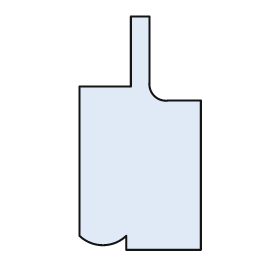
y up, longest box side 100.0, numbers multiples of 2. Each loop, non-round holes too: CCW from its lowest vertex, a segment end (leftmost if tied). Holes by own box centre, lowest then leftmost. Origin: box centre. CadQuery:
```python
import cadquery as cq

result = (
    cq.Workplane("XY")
    .moveTo(-6.0, -50.0)
    .lineTo(26.0, -50.0)
    .lineTo(26.0, 14.0)
    .lineTo(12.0, 14.0)
    .threePointArc((6.0, 16.0), (4.0, 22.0))
    .lineTo(4.0, 50.0)
    .lineTo(-4.0, 50.0)
    .lineTo(-4.0, 20.0)
    .lineTo(-26.0, 20.0)
    .lineTo(-26.0, -44.0)
    .threePointArc((-16.0, -48.0), (-6.0, -44.0))
    .close()
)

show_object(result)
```